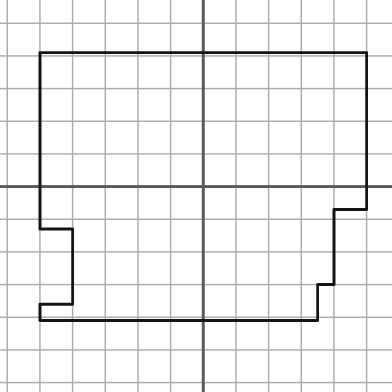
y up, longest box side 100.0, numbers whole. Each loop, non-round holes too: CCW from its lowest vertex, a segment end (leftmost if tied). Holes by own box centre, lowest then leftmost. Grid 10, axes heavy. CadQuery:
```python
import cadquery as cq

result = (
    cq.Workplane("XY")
    .moveTo(-50.0, -41.0)
    .lineTo(35.0, -41.0)
    .lineTo(35.0, -30.0)
    .lineTo(40.0, -30.0)
    .lineTo(40.0, -7.0)
    .lineTo(50.0, -7.0)
    .lineTo(50.0, 41.0)
    .lineTo(-50.0, 41.0)
    .lineTo(-50.0, -13.0)
    .lineTo(-40.0, -13.0)
    .lineTo(-40.0, -36.0)
    .lineTo(-50.0, -36.0)
    .close()
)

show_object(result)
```